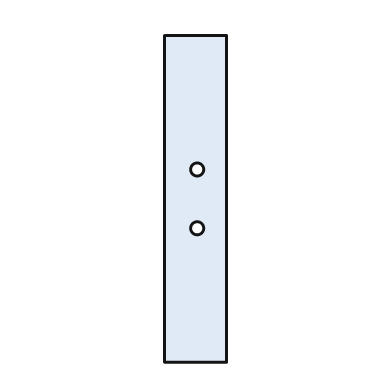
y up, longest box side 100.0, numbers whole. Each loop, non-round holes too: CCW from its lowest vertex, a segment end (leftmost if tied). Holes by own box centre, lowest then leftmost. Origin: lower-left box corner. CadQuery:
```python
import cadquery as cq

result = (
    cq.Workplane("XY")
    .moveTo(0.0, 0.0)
    .lineTo(19.0, 0.0)
    .lineTo(19.0, 100.0)
    .lineTo(0.0, 100.0)
    .close()
    .moveTo(10.0, 41.0)
    .circle(2.0)
    .moveTo(10.0, 59.0)
    .circle(2.0)
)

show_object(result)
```